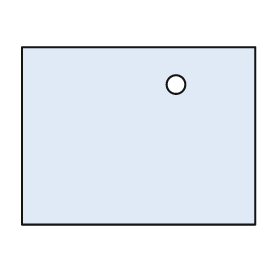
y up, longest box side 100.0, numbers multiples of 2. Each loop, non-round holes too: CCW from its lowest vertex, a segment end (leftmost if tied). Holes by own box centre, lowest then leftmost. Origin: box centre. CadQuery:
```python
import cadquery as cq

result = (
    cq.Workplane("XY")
    .moveTo(-50.0, -38.0)
    .lineTo(50.0, -38.0)
    .lineTo(50.0, 38.0)
    .lineTo(-50.0, 38.0)
    .close()
    .moveTo(16.0, 22.0)
    .circle(4.0)
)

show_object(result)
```